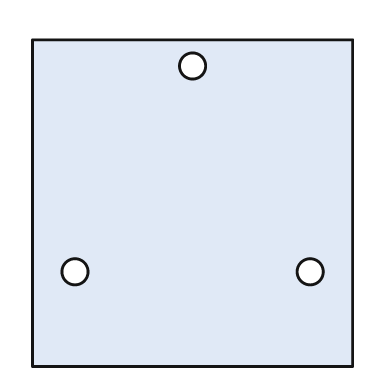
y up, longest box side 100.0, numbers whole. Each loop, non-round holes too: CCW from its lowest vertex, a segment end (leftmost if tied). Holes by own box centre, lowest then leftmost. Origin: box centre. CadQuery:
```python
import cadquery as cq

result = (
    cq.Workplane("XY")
    .moveTo(-49.0, -50.0)
    .lineTo(49.0, -50.0)
    .lineTo(49.0, 50.0)
    .lineTo(-49.0, 50.0)
    .close()
    .moveTo(-36.0, -21.0)
    .circle(4.0)
    .moveTo(36.0, -21.0)
    .circle(4.0)
    .moveTo(0.0, 42.0)
    .circle(4.0)
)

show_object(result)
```